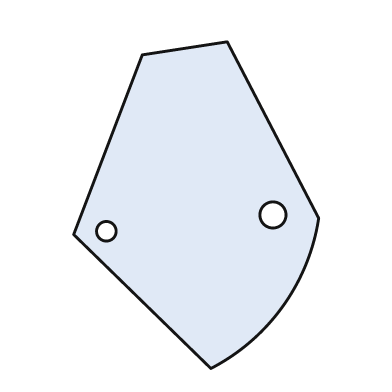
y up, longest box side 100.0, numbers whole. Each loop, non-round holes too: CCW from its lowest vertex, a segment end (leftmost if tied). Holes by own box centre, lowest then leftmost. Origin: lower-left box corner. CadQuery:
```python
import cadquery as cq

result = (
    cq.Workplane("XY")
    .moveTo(42.0, 0.0)
    .threePointArc((64.0, 19.0), (75.0, 46.0))
    .lineTo(47.0, 100.0)
    .lineTo(21.0, 96.0)
    .lineTo(0.0, 41.0)
    .close()
    .moveTo(10.0, 42.0)
    .circle(3.0)
    .moveTo(61.0, 47.0)
    .circle(4.0)
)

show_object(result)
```